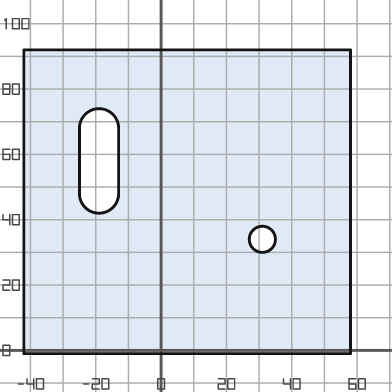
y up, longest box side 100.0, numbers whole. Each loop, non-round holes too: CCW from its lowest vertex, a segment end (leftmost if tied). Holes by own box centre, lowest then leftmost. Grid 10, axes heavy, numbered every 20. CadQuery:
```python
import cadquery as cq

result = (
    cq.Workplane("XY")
    .moveTo(-42.0, -1.0)
    .lineTo(58.0, -1.0)
    .lineTo(58.0, 92.0)
    .lineTo(-42.0, 92.0)
    .close()
    .moveTo(31.0, 34.0)
    .circle(4.0)
    .moveTo(-25.0, 48.0)
    .threePointArc((-19.0, 42.0), (-13.0, 48.0))
    .lineTo(-13.0, 68.0)
    .threePointArc((-19.0, 74.0), (-25.0, 68.0))
    .close()
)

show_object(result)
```